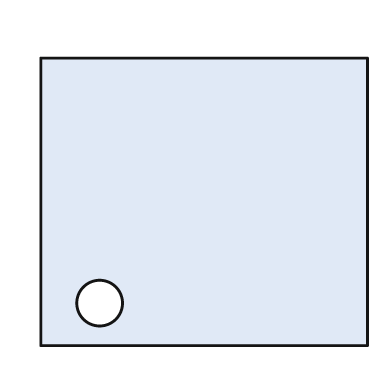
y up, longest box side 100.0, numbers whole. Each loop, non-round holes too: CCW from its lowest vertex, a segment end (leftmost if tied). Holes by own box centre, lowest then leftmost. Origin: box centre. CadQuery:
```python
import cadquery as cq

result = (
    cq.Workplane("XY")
    .moveTo(-50.0, -44.0)
    .lineTo(50.0, -44.0)
    .lineTo(50.0, 44.0)
    .lineTo(-50.0, 44.0)
    .close()
    .moveTo(-32.0, -31.0)
    .circle(7.0)
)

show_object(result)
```